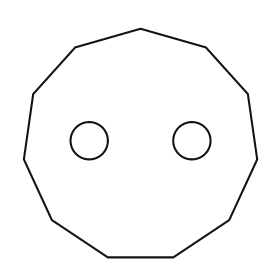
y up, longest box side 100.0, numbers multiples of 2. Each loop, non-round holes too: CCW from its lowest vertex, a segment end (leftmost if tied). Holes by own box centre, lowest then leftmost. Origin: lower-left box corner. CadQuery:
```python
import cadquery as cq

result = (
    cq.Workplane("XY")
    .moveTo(36.0, 0.0)
    .lineTo(64.0, 0.0)
    .lineTo(88.0, 16.0)
    .lineTo(100.0, 42.0)
    .lineTo(96.0, 70.0)
    .lineTo(78.0, 90.0)
    .lineTo(50.0, 98.0)
    .lineTo(22.0, 90.0)
    .lineTo(4.0, 70.0)
    .lineTo(0.0, 42.0)
    .lineTo(12.0, 16.0)
    .close()
    .moveTo(28.0, 50.0)
    .circle(8.0)
    .moveTo(72.0, 50.0)
    .circle(8.0)
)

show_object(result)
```